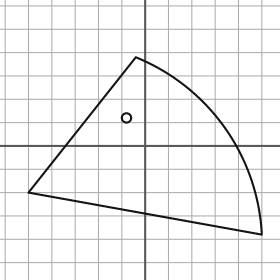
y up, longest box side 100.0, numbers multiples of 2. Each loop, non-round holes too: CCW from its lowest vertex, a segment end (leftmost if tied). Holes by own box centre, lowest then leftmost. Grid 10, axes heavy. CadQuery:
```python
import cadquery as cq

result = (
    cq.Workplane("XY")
    .moveTo(50.0, -38.0)
    .threePointArc((34.0, 8.0), (-4.0, 38.0))
    .lineTo(-50.0, -20.0)
    .close()
    .moveTo(-8.0, 12.0)
    .circle(2.0)
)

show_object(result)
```